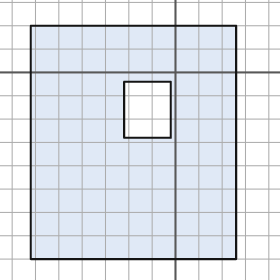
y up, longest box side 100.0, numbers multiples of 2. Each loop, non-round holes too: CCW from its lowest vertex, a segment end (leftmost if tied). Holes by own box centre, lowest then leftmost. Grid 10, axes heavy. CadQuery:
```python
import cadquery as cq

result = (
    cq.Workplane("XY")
    .moveTo(-62.0, -80.0)
    .lineTo(26.0, -80.0)
    .lineTo(26.0, 20.0)
    .lineTo(-62.0, 20.0)
    .close()
    .moveTo(-22.0, -28.0)
    .lineTo(-2.0, -28.0)
    .lineTo(-2.0, -4.0)
    .lineTo(-22.0, -4.0)
    .close()
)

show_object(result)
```